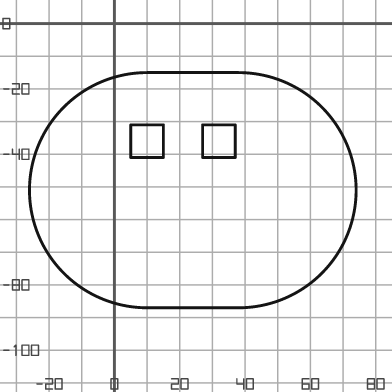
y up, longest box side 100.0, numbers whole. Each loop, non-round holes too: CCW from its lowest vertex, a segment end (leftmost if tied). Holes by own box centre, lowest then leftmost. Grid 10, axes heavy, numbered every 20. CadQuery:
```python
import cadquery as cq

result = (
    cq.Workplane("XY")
    .moveTo(10.0, -87.0)
    .lineTo(38.0, -87.0)
    .threePointArc((74.0, -51.0), (38.0, -15.0))
    .lineTo(10.0, -15.0)
    .threePointArc((-26.0, -51.0), (10.0, -87.0))
    .close()
    .moveTo(5.0, -41.0)
    .lineTo(15.0, -41.0)
    .lineTo(15.0, -31.0)
    .lineTo(5.0, -31.0)
    .close()
    .moveTo(27.0, -41.0)
    .lineTo(37.0, -41.0)
    .lineTo(37.0, -31.0)
    .lineTo(27.0, -31.0)
    .close()
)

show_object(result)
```